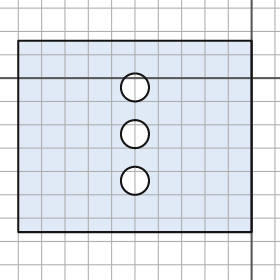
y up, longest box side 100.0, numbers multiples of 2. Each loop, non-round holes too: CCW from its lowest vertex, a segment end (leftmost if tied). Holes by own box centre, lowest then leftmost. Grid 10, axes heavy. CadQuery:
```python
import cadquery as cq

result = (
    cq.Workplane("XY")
    .moveTo(-100.0, -66.0)
    .lineTo(0.0, -66.0)
    .lineTo(0.0, 16.0)
    .lineTo(-100.0, 16.0)
    .close()
    .moveTo(-50.0, -44.0)
    .circle(6.0)
    .moveTo(-50.0, -24.0)
    .circle(6.0)
    .moveTo(-50.0, -4.0)
    .circle(6.0)
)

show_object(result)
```